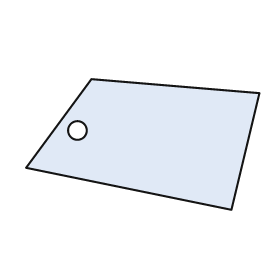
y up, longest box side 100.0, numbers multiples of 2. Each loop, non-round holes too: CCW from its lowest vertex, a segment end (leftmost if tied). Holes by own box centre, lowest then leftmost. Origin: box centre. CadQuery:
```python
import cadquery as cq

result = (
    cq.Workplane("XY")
    .moveTo(38.0, -28.0)
    .lineTo(50.0, 22.0)
    .lineTo(-22.0, 28.0)
    .lineTo(-50.0, -10.0)
    .close()
    .moveTo(-28.0, 6.0)
    .circle(4.0)
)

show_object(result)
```